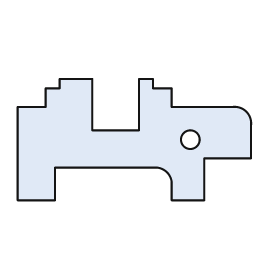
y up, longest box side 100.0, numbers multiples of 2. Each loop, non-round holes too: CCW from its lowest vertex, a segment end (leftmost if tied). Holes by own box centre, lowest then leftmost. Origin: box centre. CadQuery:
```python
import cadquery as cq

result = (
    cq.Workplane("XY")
    .moveTo(-50.0, -26.0)
    .lineTo(-34.0, -26.0)
    .lineTo(-34.0, -12.0)
    .lineTo(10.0, -12.0)
    .threePointArc((14.0, -14.0), (16.0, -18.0))
    .lineTo(16.0, -26.0)
    .lineTo(30.0, -26.0)
    .lineTo(30.0, -8.0)
    .lineTo(50.0, -8.0)
    .lineTo(50.0, 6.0)
    .threePointArc((48.0, 12.0), (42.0, 14.0))
    .lineTo(16.0, 14.0)
    .lineTo(16.0, 22.0)
    .lineTo(8.0, 22.0)
    .lineTo(8.0, 26.0)
    .lineTo(2.0, 26.0)
    .lineTo(2.0, 4.0)
    .lineTo(-18.0, 4.0)
    .lineTo(-18.0, 26.0)
    .lineTo(-32.0, 26.0)
    .lineTo(-32.0, 22.0)
    .lineTo(-38.0, 22.0)
    .lineTo(-38.0, 14.0)
    .lineTo(-50.0, 14.0)
    .close()
    .moveTo(24.0, 0.0)
    .circle(4.0)
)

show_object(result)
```